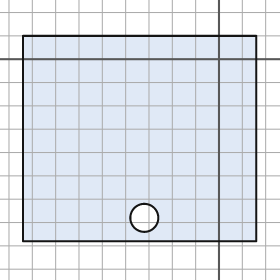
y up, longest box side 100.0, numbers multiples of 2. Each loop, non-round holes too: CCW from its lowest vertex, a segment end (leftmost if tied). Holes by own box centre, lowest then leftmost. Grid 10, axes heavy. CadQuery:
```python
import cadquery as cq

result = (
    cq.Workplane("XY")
    .moveTo(-84.0, -78.0)
    .lineTo(16.0, -78.0)
    .lineTo(16.0, 10.0)
    .lineTo(-84.0, 10.0)
    .close()
    .moveTo(-32.0, -68.0)
    .circle(6.0)
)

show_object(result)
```